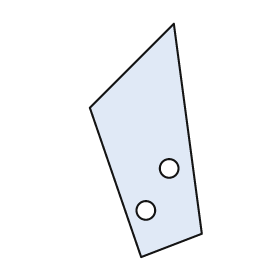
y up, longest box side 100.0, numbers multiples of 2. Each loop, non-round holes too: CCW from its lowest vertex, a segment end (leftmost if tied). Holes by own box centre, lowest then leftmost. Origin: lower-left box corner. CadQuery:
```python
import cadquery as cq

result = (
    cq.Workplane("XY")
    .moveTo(22.0, 0.0)
    .lineTo(48.0, 10.0)
    .lineTo(36.0, 100.0)
    .lineTo(0.0, 64.0)
    .close()
    .moveTo(24.0, 20.0)
    .circle(4.0)
    .moveTo(34.0, 38.0)
    .circle(4.0)
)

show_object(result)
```